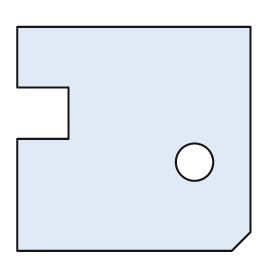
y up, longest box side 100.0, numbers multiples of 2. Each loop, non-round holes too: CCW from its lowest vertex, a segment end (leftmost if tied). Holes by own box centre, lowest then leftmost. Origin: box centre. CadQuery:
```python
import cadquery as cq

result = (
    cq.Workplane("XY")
    .moveTo(-50.0, -48.0)
    .lineTo(42.0, -48.0)
    .lineTo(50.0, -40.0)
    .lineTo(50.0, 48.0)
    .lineTo(-50.0, 48.0)
    .lineTo(-50.0, 22.0)
    .lineTo(-28.0, 22.0)
    .lineTo(-28.0, 0.0)
    .lineTo(-50.0, 0.0)
    .close()
    .moveTo(26.0, -10.0)
    .circle(8.0)
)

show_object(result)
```